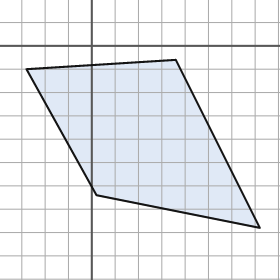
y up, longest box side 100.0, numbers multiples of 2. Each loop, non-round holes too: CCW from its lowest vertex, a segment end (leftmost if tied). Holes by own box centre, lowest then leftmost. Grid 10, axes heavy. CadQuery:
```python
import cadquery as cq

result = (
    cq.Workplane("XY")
    .moveTo(72.0, -78.0)
    .lineTo(36.0, -6.0)
    .lineTo(-28.0, -10.0)
    .lineTo(2.0, -64.0)
    .close()
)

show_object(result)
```